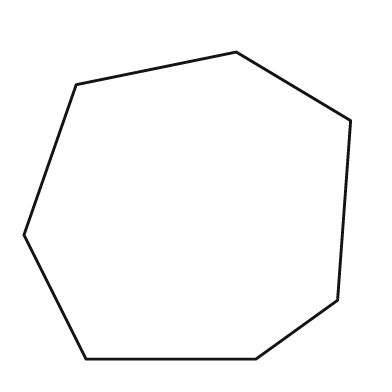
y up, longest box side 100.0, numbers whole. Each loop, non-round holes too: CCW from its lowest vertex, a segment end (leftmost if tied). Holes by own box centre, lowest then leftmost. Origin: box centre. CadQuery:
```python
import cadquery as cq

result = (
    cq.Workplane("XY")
    .moveTo(-31.0, -47.0)
    .lineTo(21.0, -47.0)
    .lineTo(46.0, -29.0)
    .lineTo(50.0, 26.0)
    .lineTo(15.0, 47.0)
    .lineTo(-34.0, 37.0)
    .lineTo(-50.0, -9.0)
    .close()
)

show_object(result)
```